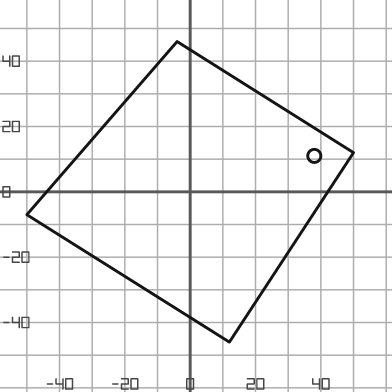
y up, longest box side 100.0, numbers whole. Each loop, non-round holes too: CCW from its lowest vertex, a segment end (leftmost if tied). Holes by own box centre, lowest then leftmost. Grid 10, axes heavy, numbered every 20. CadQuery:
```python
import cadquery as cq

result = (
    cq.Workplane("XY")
    .moveTo(12.0, -46.0)
    .lineTo(50.0, 12.0)
    .lineTo(-4.0, 46.0)
    .lineTo(-50.0, -7.0)
    .close()
    .moveTo(38.0, 11.0)
    .circle(2.0)
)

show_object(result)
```